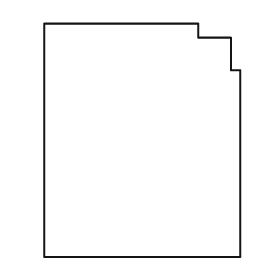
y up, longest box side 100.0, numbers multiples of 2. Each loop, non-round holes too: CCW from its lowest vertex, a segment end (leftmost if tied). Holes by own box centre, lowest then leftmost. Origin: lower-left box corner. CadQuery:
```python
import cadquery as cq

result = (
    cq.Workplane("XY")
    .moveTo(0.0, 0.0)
    .lineTo(84.0, 0.0)
    .lineTo(84.0, 80.0)
    .lineTo(80.0, 80.0)
    .lineTo(80.0, 94.0)
    .lineTo(66.0, 94.0)
    .lineTo(66.0, 100.0)
    .lineTo(0.0, 100.0)
    .close()
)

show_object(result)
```